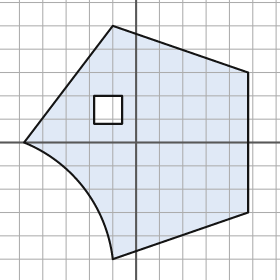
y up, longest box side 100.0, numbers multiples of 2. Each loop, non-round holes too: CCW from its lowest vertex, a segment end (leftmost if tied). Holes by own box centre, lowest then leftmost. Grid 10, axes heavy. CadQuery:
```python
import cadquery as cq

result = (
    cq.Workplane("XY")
    .moveTo(-10.0, -50.0)
    .lineTo(48.0, -30.0)
    .lineTo(48.0, 30.0)
    .lineTo(-10.0, 50.0)
    .lineTo(-48.0, 0.0)
    .threePointArc((-22.0, -20.0), (-10.0, -50.0))
    .close()
    .moveTo(-18.0, 8.0)
    .lineTo(-6.0, 8.0)
    .lineTo(-6.0, 20.0)
    .lineTo(-18.0, 20.0)
    .close()
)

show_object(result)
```